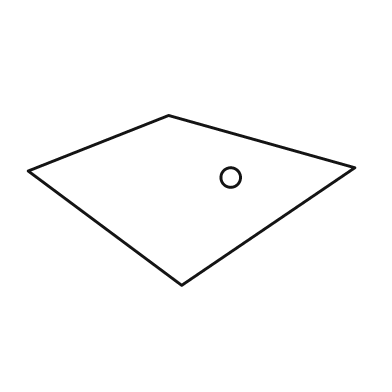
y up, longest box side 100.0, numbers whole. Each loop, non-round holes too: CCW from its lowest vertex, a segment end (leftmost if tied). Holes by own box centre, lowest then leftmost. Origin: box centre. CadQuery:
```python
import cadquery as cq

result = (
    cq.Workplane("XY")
    .moveTo(-3.0, -26.0)
    .lineTo(50.0, 10.0)
    .lineTo(-7.0, 26.0)
    .lineTo(-50.0, 9.0)
    .close()
    .moveTo(12.0, 7.0)
    .circle(3.0)
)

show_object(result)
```